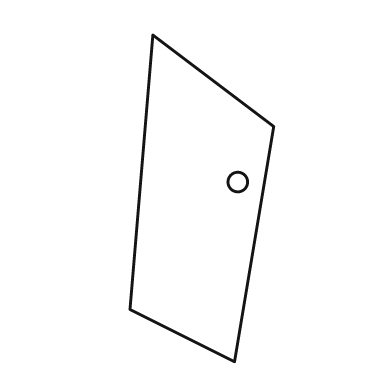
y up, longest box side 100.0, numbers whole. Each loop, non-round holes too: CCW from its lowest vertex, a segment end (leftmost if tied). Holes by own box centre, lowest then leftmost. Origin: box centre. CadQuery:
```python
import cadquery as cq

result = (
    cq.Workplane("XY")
    .moveTo(10.0, -50.0)
    .lineTo(22.0, 22.0)
    .lineTo(-15.0, 50.0)
    .lineTo(-22.0, -34.0)
    .close()
    .moveTo(11.0, 5.0)
    .circle(3.0)
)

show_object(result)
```